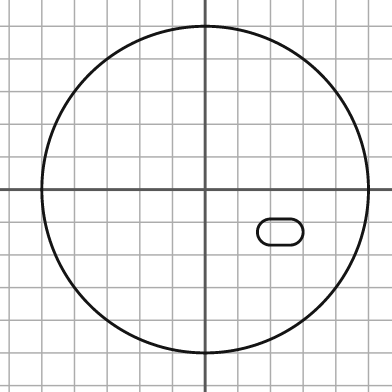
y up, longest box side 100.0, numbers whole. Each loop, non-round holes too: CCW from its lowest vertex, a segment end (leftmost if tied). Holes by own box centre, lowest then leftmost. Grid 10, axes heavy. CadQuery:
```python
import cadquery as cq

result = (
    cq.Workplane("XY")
    .moveTo(0.0, 0.0)
    .circle(50.0)
    .moveTo(20.0, -17.0)
    .lineTo(26.0, -17.0)
    .threePointArc((30.0, -13.0), (26.0, -9.0))
    .lineTo(20.0, -9.0)
    .threePointArc((16.0, -13.0), (20.0, -17.0))
    .close()
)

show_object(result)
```